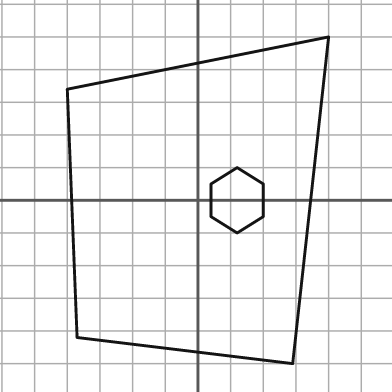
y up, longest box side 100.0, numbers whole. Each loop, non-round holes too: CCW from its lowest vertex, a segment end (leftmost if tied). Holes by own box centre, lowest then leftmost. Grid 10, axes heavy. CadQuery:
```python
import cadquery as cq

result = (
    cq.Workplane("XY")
    .moveTo(29.0, -50.0)
    .lineTo(40.0, 50.0)
    .lineTo(-40.0, 34.0)
    .lineTo(-37.0, -42.0)
    .close()
    .moveTo(12.0, -10.0)
    .lineTo(20.0, -5.0)
    .lineTo(20.0, 5.0)
    .lineTo(12.0, 10.0)
    .lineTo(4.0, 5.0)
    .lineTo(4.0, -5.0)
    .close()
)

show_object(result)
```